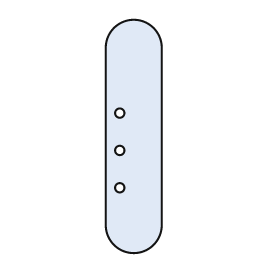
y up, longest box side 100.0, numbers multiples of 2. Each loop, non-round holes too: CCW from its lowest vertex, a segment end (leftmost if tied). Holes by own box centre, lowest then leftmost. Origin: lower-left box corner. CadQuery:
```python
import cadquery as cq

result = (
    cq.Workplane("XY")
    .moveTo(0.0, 12.0)
    .threePointArc((12.0, 0.0), (24.0, 12.0))
    .lineTo(24.0, 88.0)
    .threePointArc((12.0, 100.0), (0.0, 88.0))
    .close()
    .moveTo(6.0, 28.0)
    .circle(2.0)
    .moveTo(6.0, 44.0)
    .circle(2.0)
    .moveTo(6.0, 60.0)
    .circle(2.0)
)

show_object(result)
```